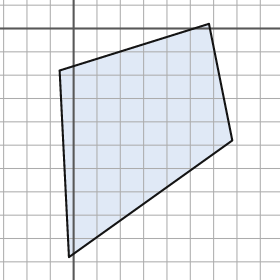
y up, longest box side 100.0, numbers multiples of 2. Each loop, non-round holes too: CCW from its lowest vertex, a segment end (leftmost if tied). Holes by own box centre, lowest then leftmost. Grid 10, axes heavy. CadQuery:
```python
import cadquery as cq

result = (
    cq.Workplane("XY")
    .moveTo(-2.0, -98.0)
    .lineTo(68.0, -48.0)
    .lineTo(58.0, 2.0)
    .lineTo(-6.0, -18.0)
    .close()
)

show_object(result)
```